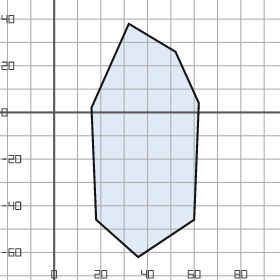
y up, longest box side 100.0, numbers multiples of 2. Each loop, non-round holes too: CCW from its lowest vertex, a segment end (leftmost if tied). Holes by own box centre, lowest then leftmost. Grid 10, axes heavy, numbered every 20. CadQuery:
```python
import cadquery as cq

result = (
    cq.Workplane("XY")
    .moveTo(36.0, -62.0)
    .lineTo(60.0, -46.0)
    .lineTo(62.0, 4.0)
    .lineTo(52.0, 26.0)
    .lineTo(32.0, 38.0)
    .lineTo(16.0, 2.0)
    .lineTo(18.0, -46.0)
    .close()
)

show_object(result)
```